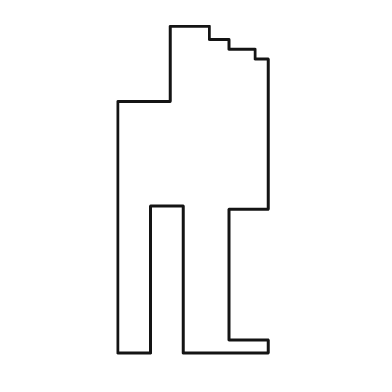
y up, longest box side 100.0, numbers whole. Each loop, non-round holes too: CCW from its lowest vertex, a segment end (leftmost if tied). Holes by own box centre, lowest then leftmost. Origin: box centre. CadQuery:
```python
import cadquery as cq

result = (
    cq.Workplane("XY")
    .moveTo(-23.0, -50.0)
    .lineTo(-13.0, -50.0)
    .lineTo(-13.0, -5.0)
    .lineTo(-3.0, -5.0)
    .lineTo(-3.0, -50.0)
    .lineTo(23.0, -50.0)
    .lineTo(23.0, -46.0)
    .lineTo(11.0, -46.0)
    .lineTo(11.0, -6.0)
    .lineTo(23.0, -6.0)
    .lineTo(23.0, 40.0)
    .lineTo(19.0, 40.0)
    .lineTo(19.0, 43.0)
    .lineTo(11.0, 43.0)
    .lineTo(11.0, 46.0)
    .lineTo(5.0, 46.0)
    .lineTo(5.0, 50.0)
    .lineTo(-7.0, 50.0)
    .lineTo(-7.0, 27.0)
    .lineTo(-23.0, 27.0)
    .close()
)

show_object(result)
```